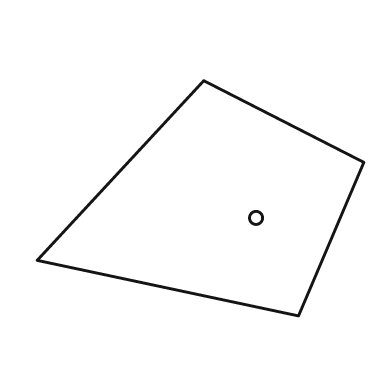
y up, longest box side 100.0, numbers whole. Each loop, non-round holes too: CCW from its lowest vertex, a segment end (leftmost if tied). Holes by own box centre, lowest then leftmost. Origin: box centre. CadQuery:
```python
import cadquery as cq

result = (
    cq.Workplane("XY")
    .moveTo(30.0, -36.0)
    .lineTo(50.0, 11.0)
    .lineTo(1.0, 36.0)
    .lineTo(-50.0, -19.0)
    .close()
    .moveTo(17.0, -6.0)
    .circle(2.0)
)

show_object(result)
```